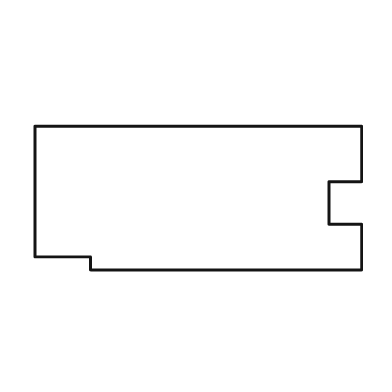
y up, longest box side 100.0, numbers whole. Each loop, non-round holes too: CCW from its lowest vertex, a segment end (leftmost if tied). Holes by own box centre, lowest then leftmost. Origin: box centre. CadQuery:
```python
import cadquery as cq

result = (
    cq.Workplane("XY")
    .moveTo(-33.0, -22.0)
    .lineTo(50.0, -22.0)
    .lineTo(50.0, -8.0)
    .lineTo(40.0, -8.0)
    .lineTo(40.0, 5.0)
    .lineTo(50.0, 5.0)
    .lineTo(50.0, 22.0)
    .lineTo(-50.0, 22.0)
    .lineTo(-50.0, -18.0)
    .lineTo(-33.0, -18.0)
    .close()
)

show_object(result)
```